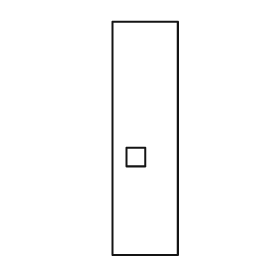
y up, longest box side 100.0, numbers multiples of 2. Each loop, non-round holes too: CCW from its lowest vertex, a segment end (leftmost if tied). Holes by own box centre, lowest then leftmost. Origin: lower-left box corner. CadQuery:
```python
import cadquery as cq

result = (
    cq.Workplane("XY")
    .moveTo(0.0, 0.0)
    .lineTo(28.0, 0.0)
    .lineTo(28.0, 100.0)
    .lineTo(0.0, 100.0)
    .close()
    .moveTo(6.0, 38.0)
    .lineTo(14.0, 38.0)
    .lineTo(14.0, 46.0)
    .lineTo(6.0, 46.0)
    .close()
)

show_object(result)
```